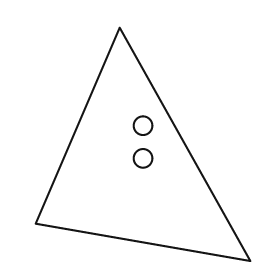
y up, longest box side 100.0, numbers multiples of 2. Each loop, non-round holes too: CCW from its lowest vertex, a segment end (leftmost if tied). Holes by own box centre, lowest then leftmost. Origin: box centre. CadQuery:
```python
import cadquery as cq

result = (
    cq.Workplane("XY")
    .moveTo(46.0, -50.0)
    .lineTo(-10.0, 50.0)
    .lineTo(-46.0, -34.0)
    .close()
    .moveTo(0.0, -6.0)
    .circle(4.0)
    .moveTo(0.0, 8.0)
    .circle(4.0)
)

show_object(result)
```